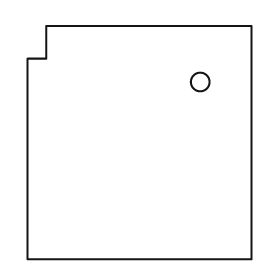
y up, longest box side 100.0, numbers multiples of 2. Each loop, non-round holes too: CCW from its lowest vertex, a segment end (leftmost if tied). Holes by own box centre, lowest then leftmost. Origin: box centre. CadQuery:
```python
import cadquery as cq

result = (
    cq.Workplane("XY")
    .moveTo(-48.0, -50.0)
    .lineTo(48.0, -50.0)
    .lineTo(48.0, 50.0)
    .lineTo(-40.0, 50.0)
    .lineTo(-40.0, 36.0)
    .lineTo(-48.0, 36.0)
    .close()
    .moveTo(26.0, 26.0)
    .circle(4.0)
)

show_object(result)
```